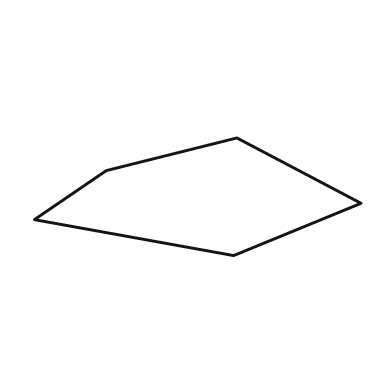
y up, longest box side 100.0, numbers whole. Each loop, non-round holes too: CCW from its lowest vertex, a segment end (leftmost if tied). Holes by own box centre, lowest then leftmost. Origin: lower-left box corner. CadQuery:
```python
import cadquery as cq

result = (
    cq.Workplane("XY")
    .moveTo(61.0, 0.0)
    .lineTo(100.0, 16.0)
    .lineTo(62.0, 36.0)
    .lineTo(22.0, 26.0)
    .lineTo(0.0, 11.0)
    .close()
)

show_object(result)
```